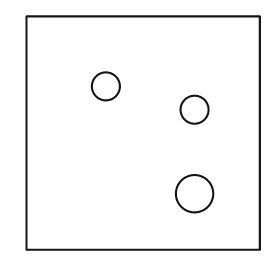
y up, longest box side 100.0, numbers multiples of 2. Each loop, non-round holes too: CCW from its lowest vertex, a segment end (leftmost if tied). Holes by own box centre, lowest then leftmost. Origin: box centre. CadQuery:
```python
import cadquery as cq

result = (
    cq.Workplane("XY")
    .moveTo(-50.0, -50.0)
    .lineTo(50.0, -50.0)
    .lineTo(50.0, 50.0)
    .lineTo(-50.0, 50.0)
    .close()
    .moveTo(22.0, -26.0)
    .circle(8.0)
    .moveTo(22.0, 10.0)
    .circle(6.0)
    .moveTo(-16.0, 20.0)
    .circle(6.0)
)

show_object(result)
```